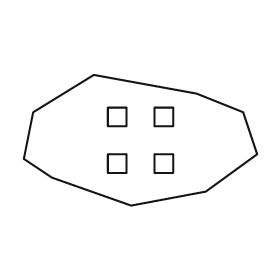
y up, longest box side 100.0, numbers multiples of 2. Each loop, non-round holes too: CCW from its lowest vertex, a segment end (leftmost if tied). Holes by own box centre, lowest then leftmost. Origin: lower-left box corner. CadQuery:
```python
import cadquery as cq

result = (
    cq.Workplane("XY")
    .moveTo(46.0, 0.0)
    .lineTo(78.0, 6.0)
    .lineTo(100.0, 22.0)
    .lineTo(94.0, 40.0)
    .lineTo(74.0, 48.0)
    .lineTo(30.0, 56.0)
    .lineTo(4.0, 40.0)
    .lineTo(0.0, 20.0)
    .lineTo(12.0, 12.0)
    .close()
    .moveTo(36.0, 14.0)
    .lineTo(44.0, 14.0)
    .lineTo(44.0, 22.0)
    .lineTo(36.0, 22.0)
    .close()
    .moveTo(56.0, 14.0)
    .lineTo(64.0, 14.0)
    .lineTo(64.0, 22.0)
    .lineTo(56.0, 22.0)
    .close()
    .moveTo(36.0, 34.0)
    .lineTo(44.0, 34.0)
    .lineTo(44.0, 42.0)
    .lineTo(36.0, 42.0)
    .close()
    .moveTo(56.0, 34.0)
    .lineTo(64.0, 34.0)
    .lineTo(64.0, 42.0)
    .lineTo(56.0, 42.0)
    .close()
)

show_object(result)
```